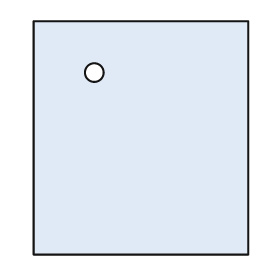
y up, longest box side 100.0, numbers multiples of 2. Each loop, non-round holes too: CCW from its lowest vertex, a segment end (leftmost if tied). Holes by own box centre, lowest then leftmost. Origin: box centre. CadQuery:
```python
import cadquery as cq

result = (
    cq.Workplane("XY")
    .moveTo(-46.0, -50.0)
    .lineTo(46.0, -50.0)
    .lineTo(46.0, 50.0)
    .lineTo(-46.0, 50.0)
    .close()
    .moveTo(-20.0, 28.0)
    .circle(4.0)
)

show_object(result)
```